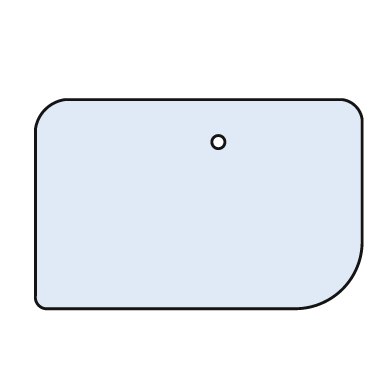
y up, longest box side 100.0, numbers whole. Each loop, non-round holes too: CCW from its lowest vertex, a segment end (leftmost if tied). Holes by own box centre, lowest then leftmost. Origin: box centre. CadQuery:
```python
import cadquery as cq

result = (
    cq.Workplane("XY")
    .moveTo(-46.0, -32.0)
    .lineTo(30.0, -32.0)
    .threePointArc((44.0, -26.0), (50.0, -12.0))
    .lineTo(50.0, 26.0)
    .threePointArc((48.0, 30.0), (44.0, 32.0))
    .lineTo(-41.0, 32.0)
    .threePointArc((-47.0, 29.0), (-50.0, 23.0))
    .lineTo(-50.0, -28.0)
    .threePointArc((-49.0, -31.0), (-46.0, -32.0))
    .close()
    .moveTo(6.0, 19.0)
    .circle(2.0)
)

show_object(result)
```